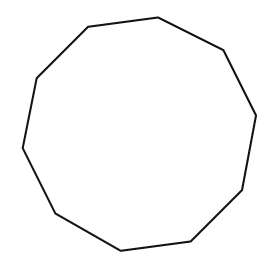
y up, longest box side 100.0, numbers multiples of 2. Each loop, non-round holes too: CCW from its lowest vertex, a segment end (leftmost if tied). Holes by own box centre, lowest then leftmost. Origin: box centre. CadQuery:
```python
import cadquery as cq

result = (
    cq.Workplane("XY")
    .moveTo(-8.0, -50.0)
    .lineTo(22.0, -46.0)
    .lineTo(44.0, -24.0)
    .lineTo(50.0, 8.0)
    .lineTo(36.0, 36.0)
    .lineTo(8.0, 50.0)
    .lineTo(-22.0, 46.0)
    .lineTo(-44.0, 24.0)
    .lineTo(-50.0, -6.0)
    .lineTo(-36.0, -34.0)
    .close()
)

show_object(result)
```